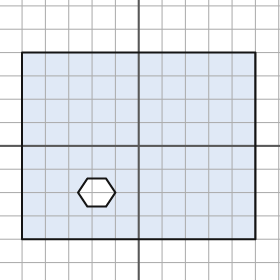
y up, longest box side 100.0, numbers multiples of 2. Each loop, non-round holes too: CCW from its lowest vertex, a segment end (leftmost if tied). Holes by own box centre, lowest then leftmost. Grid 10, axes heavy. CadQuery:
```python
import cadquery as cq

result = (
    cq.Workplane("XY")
    .moveTo(-50.0, -40.0)
    .lineTo(50.0, -40.0)
    .lineTo(50.0, 40.0)
    .lineTo(-50.0, 40.0)
    .close()
    .moveTo(-22.0, -26.0)
    .lineTo(-14.0, -26.0)
    .lineTo(-10.0, -20.0)
    .lineTo(-14.0, -14.0)
    .lineTo(-22.0, -14.0)
    .lineTo(-26.0, -20.0)
    .close()
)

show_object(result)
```